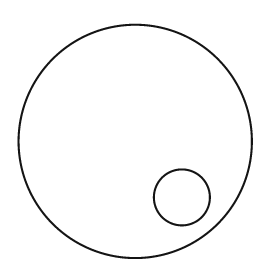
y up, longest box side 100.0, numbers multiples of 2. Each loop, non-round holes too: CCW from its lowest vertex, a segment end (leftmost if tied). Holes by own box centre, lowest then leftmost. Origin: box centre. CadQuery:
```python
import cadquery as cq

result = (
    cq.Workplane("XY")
    .moveTo(0.0, 0.0)
    .circle(50.0)
    .moveTo(20.0, -24.0)
    .circle(12.0)
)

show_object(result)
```